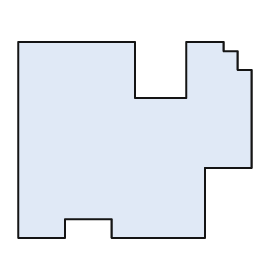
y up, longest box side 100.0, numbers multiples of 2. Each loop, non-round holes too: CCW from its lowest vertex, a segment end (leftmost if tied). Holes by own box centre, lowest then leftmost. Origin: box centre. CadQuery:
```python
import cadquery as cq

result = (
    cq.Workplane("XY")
    .moveTo(-50.0, -42.0)
    .lineTo(-30.0, -42.0)
    .lineTo(-30.0, -34.0)
    .lineTo(-10.0, -34.0)
    .lineTo(-10.0, -42.0)
    .lineTo(30.0, -42.0)
    .lineTo(30.0, -12.0)
    .lineTo(50.0, -12.0)
    .lineTo(50.0, 30.0)
    .lineTo(44.0, 30.0)
    .lineTo(44.0, 38.0)
    .lineTo(38.0, 38.0)
    .lineTo(38.0, 42.0)
    .lineTo(22.0, 42.0)
    .lineTo(22.0, 18.0)
    .lineTo(0.0, 18.0)
    .lineTo(0.0, 42.0)
    .lineTo(-50.0, 42.0)
    .close()
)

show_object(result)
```